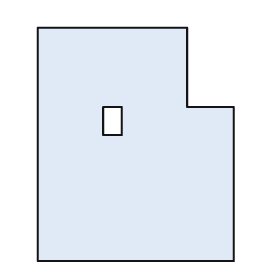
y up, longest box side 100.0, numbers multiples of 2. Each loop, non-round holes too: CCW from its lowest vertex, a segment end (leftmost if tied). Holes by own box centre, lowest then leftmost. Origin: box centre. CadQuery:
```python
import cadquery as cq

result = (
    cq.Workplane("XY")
    .moveTo(-42.0, -50.0)
    .lineTo(42.0, -50.0)
    .lineTo(42.0, 16.0)
    .lineTo(22.0, 16.0)
    .lineTo(22.0, 50.0)
    .lineTo(-42.0, 50.0)
    .close()
    .moveTo(-14.0, 4.0)
    .lineTo(-6.0, 4.0)
    .lineTo(-6.0, 16.0)
    .lineTo(-14.0, 16.0)
    .close()
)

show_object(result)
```